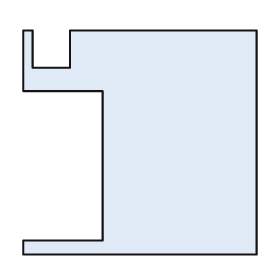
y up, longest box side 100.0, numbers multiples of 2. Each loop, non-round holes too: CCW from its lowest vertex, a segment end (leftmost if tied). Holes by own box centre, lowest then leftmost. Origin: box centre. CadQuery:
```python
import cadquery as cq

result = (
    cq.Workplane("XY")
    .moveTo(-50.0, -48.0)
    .lineTo(50.0, -48.0)
    .lineTo(50.0, 48.0)
    .lineTo(-30.0, 48.0)
    .lineTo(-30.0, 32.0)
    .lineTo(-46.0, 32.0)
    .lineTo(-46.0, 48.0)
    .lineTo(-50.0, 48.0)
    .lineTo(-50.0, 22.0)
    .lineTo(-16.0, 22.0)
    .lineTo(-16.0, -42.0)
    .lineTo(-50.0, -42.0)
    .close()
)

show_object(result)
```